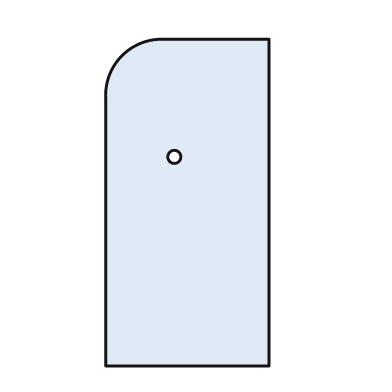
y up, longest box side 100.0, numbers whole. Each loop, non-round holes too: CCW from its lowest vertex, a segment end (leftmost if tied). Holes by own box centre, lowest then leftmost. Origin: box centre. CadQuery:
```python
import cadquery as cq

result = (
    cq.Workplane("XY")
    .moveTo(-25.0, -50.0)
    .lineTo(25.0, -50.0)
    .lineTo(25.0, 50.0)
    .lineTo(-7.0, 50.0)
    .threePointArc((-20.0, 45.0), (-25.0, 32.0))
    .close()
    .moveTo(-4.0, 14.0)
    .circle(2.0)
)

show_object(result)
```